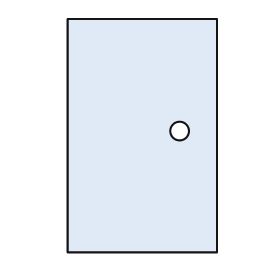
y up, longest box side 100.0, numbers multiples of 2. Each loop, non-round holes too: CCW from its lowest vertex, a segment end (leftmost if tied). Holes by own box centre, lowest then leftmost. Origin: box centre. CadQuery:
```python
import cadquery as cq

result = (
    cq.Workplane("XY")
    .moveTo(-32.0, -50.0)
    .lineTo(32.0, -50.0)
    .lineTo(32.0, 50.0)
    .lineTo(-32.0, 50.0)
    .close()
    .moveTo(16.0, 2.0)
    .circle(4.0)
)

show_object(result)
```